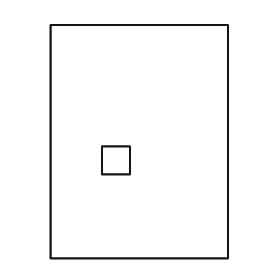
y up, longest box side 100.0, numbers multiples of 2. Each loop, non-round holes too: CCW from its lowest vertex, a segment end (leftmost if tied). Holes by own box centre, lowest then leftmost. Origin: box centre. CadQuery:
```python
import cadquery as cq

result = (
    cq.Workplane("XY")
    .moveTo(-38.0, -50.0)
    .lineTo(38.0, -50.0)
    .lineTo(38.0, 50.0)
    .lineTo(-38.0, 50.0)
    .close()
    .moveTo(-16.0, -14.0)
    .lineTo(-4.0, -14.0)
    .lineTo(-4.0, -2.0)
    .lineTo(-16.0, -2.0)
    .close()
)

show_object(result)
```